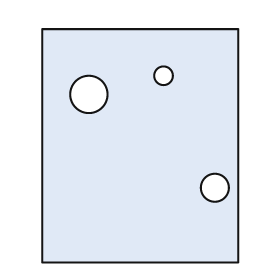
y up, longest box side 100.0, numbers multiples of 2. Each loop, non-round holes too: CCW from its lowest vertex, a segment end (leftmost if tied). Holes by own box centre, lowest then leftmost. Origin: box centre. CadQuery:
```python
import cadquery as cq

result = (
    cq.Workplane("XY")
    .moveTo(-42.0, -50.0)
    .lineTo(42.0, -50.0)
    .lineTo(42.0, 50.0)
    .lineTo(-42.0, 50.0)
    .close()
    .moveTo(32.0, -18.0)
    .circle(6.0)
    .moveTo(-22.0, 22.0)
    .circle(8.0)
    .moveTo(10.0, 30.0)
    .circle(4.0)
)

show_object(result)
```